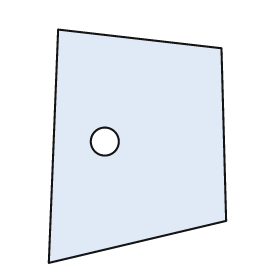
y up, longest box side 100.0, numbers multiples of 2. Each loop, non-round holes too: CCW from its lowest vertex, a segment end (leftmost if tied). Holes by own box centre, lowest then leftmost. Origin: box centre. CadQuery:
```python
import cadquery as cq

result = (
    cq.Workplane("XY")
    .moveTo(-38.0, -50.0)
    .lineTo(38.0, -32.0)
    .lineTo(36.0, 42.0)
    .lineTo(-34.0, 50.0)
    .close()
    .moveTo(-14.0, 2.0)
    .circle(6.0)
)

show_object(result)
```